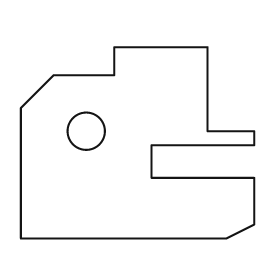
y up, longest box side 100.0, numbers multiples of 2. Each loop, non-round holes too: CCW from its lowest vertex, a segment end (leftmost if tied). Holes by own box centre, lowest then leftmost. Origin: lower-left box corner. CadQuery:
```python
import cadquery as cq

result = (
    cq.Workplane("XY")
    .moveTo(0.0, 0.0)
    .lineTo(88.0, 0.0)
    .lineTo(100.0, 6.0)
    .lineTo(100.0, 26.0)
    .lineTo(56.0, 26.0)
    .lineTo(56.0, 40.0)
    .lineTo(100.0, 40.0)
    .lineTo(100.0, 46.0)
    .lineTo(80.0, 46.0)
    .lineTo(80.0, 82.0)
    .lineTo(40.0, 82.0)
    .lineTo(40.0, 70.0)
    .lineTo(14.0, 70.0)
    .lineTo(0.0, 56.0)
    .close()
    .moveTo(28.0, 46.0)
    .circle(8.0)
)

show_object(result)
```